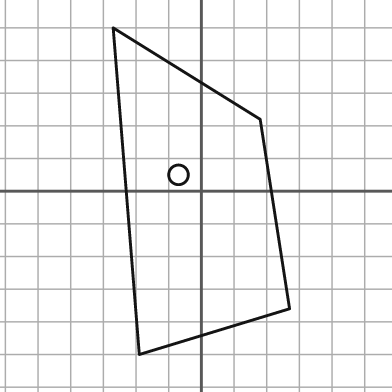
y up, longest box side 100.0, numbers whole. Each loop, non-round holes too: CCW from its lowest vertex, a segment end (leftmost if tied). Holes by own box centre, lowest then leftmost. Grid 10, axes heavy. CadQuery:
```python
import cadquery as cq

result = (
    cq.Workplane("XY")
    .moveTo(-19.0, -50.0)
    .lineTo(27.0, -36.0)
    .lineTo(18.0, 22.0)
    .lineTo(-27.0, 50.0)
    .close()
    .moveTo(-7.0, 5.0)
    .circle(3.0)
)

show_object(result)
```